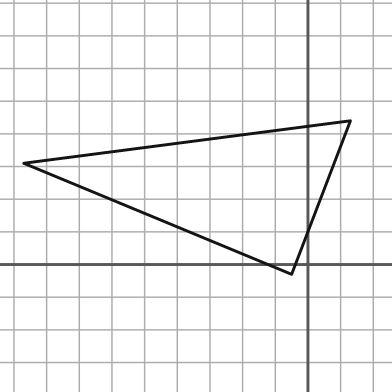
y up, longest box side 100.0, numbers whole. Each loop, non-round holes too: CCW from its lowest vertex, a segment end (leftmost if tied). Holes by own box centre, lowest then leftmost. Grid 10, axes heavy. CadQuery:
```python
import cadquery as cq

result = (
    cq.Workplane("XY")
    .moveTo(-5.0, -3.0)
    .lineTo(13.0, 44.0)
    .lineTo(-87.0, 31.0)
    .close()
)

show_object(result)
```